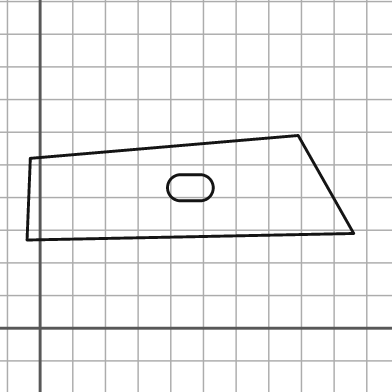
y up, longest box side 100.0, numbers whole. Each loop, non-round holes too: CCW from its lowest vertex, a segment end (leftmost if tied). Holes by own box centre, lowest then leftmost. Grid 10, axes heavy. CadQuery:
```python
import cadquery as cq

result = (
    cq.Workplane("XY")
    .moveTo(-4.0, 27.0)
    .lineTo(96.0, 29.0)
    .lineTo(79.0, 59.0)
    .lineTo(-3.0, 52.0)
    .close()
    .moveTo(43.0, 39.0)
    .lineTo(49.0, 39.0)
    .threePointArc((53.0, 43.0), (49.0, 47.0))
    .lineTo(43.0, 47.0)
    .threePointArc((39.0, 43.0), (43.0, 39.0))
    .close()
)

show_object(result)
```